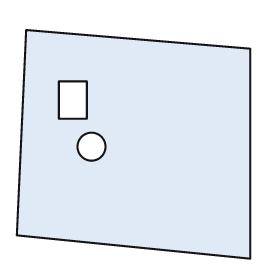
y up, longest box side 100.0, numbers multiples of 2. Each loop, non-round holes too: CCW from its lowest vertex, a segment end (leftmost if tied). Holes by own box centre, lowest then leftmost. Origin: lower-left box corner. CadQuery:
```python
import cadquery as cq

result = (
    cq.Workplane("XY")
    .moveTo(100.0, 0.0)
    .lineTo(100.0, 90.0)
    .lineTo(4.0, 98.0)
    .lineTo(0.0, 10.0)
    .close()
    .moveTo(32.0, 48.0)
    .circle(6.0)
    .moveTo(18.0, 60.0)
    .lineTo(30.0, 60.0)
    .lineTo(30.0, 76.0)
    .lineTo(18.0, 76.0)
    .close()
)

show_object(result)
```